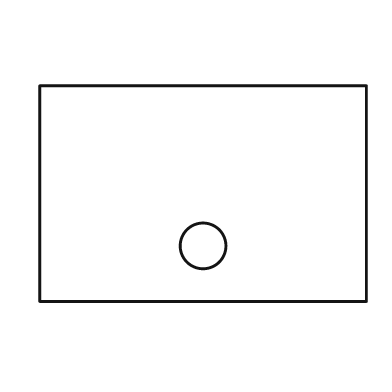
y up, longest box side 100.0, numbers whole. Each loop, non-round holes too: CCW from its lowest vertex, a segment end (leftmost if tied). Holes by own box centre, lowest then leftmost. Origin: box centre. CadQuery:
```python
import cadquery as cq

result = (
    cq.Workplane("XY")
    .moveTo(-50.0, -33.0)
    .lineTo(50.0, -33.0)
    .lineTo(50.0, 33.0)
    .lineTo(-50.0, 33.0)
    .close()
    .moveTo(0.0, -16.0)
    .circle(7.0)
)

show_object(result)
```